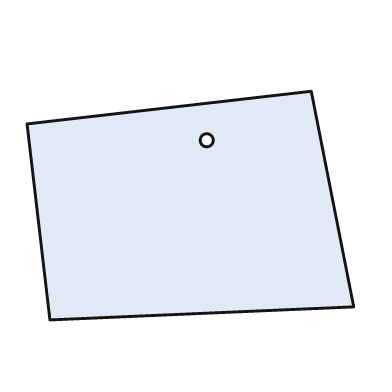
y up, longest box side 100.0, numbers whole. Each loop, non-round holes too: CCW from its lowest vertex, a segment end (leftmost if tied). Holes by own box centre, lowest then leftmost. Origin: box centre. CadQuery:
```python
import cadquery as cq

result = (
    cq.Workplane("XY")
    .moveTo(-43.0, -35.0)
    .lineTo(50.0, -31.0)
    .lineTo(37.0, 35.0)
    .lineTo(-50.0, 25.0)
    .close()
    .moveTo(5.0, 20.0)
    .circle(2.0)
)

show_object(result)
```